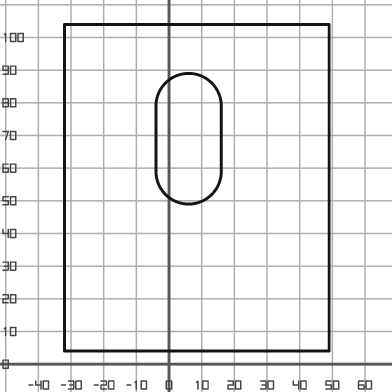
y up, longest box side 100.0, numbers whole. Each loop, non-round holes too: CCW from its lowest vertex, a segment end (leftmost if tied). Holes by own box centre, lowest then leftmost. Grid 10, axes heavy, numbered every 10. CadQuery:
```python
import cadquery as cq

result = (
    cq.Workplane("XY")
    .moveTo(-32.0, 4.0)
    .lineTo(49.0, 4.0)
    .lineTo(49.0, 104.0)
    .lineTo(-32.0, 104.0)
    .close()
    .moveTo(-4.0, 59.0)
    .threePointArc((6.0, 49.0), (16.0, 59.0))
    .lineTo(16.0, 79.0)
    .threePointArc((6.0, 89.0), (-4.0, 79.0))
    .close()
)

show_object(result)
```